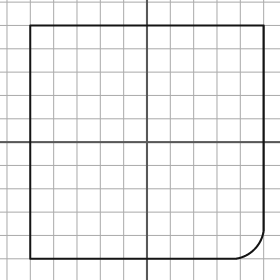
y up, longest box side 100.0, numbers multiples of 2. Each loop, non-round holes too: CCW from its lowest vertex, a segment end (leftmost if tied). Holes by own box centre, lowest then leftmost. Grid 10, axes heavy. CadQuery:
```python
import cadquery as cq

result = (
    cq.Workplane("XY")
    .moveTo(-50.0, -50.0)
    .lineTo(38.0, -50.0)
    .threePointArc((46.0, -46.0), (50.0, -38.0))
    .lineTo(50.0, 50.0)
    .lineTo(-50.0, 50.0)
    .close()
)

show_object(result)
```